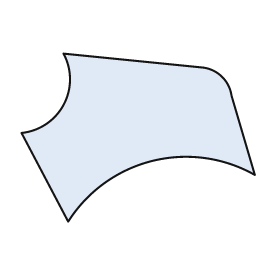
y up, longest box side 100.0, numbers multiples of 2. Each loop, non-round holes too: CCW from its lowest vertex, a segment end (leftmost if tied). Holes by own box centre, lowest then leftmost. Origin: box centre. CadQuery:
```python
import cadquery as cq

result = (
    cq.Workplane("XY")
    .moveTo(-30.0, -36.0)
    .threePointArc((6.0, -10.0), (50.0, -16.0))
    .lineTo(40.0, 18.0)
    .threePointArc((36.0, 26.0), (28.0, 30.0))
    .lineTo(-32.0, 36.0)
    .threePointArc((-32.0, 14.0), (-50.0, 2.0))
    .close()
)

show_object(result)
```